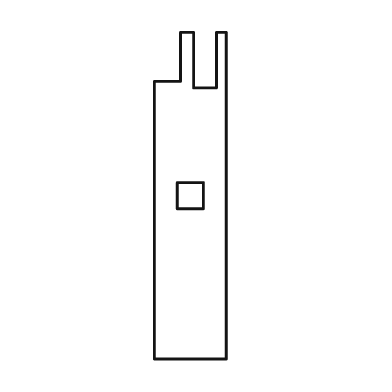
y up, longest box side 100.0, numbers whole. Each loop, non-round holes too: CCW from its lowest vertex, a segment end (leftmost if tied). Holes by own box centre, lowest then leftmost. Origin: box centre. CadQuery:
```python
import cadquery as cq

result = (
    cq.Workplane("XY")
    .moveTo(-11.0, -50.0)
    .lineTo(11.0, -50.0)
    .lineTo(11.0, 50.0)
    .lineTo(8.0, 50.0)
    .lineTo(8.0, 33.0)
    .lineTo(1.0, 33.0)
    .lineTo(1.0, 50.0)
    .lineTo(-3.0, 50.0)
    .lineTo(-3.0, 35.0)
    .lineTo(-11.0, 35.0)
    .close()
    .moveTo(-4.0, -4.0)
    .lineTo(4.0, -4.0)
    .lineTo(4.0, 4.0)
    .lineTo(-4.0, 4.0)
    .close()
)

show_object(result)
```